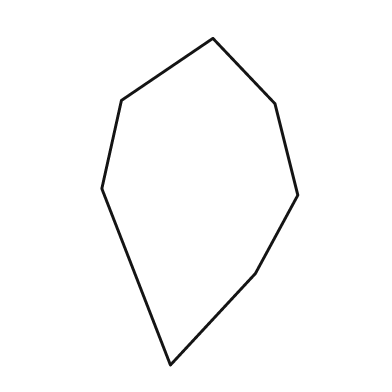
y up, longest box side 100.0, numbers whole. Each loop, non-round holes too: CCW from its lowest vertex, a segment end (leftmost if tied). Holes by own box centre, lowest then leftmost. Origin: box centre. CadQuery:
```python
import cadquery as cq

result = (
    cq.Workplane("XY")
    .moveTo(-9.0, -50.0)
    .lineTo(17.0, -22.0)
    .lineTo(30.0, 2.0)
    .lineTo(23.0, 30.0)
    .lineTo(4.0, 50.0)
    .lineTo(-24.0, 31.0)
    .lineTo(-30.0, 4.0)
    .close()
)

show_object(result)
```